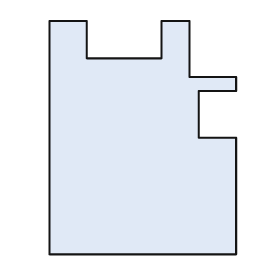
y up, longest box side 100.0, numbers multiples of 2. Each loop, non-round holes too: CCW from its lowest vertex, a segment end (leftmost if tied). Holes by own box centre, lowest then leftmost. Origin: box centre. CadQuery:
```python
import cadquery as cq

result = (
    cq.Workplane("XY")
    .moveTo(-40.0, -50.0)
    .lineTo(40.0, -50.0)
    .lineTo(40.0, 0.0)
    .lineTo(24.0, 0.0)
    .lineTo(24.0, 20.0)
    .lineTo(40.0, 20.0)
    .lineTo(40.0, 26.0)
    .lineTo(20.0, 26.0)
    .lineTo(20.0, 50.0)
    .lineTo(8.0, 50.0)
    .lineTo(8.0, 34.0)
    .lineTo(-24.0, 34.0)
    .lineTo(-24.0, 50.0)
    .lineTo(-40.0, 50.0)
    .close()
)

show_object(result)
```